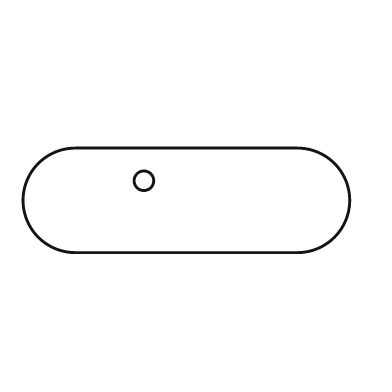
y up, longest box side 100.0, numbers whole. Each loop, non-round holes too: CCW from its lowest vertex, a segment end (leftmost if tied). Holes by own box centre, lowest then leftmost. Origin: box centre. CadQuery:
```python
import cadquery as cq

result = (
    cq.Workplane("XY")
    .moveTo(-34.0, -16.0)
    .lineTo(34.0, -16.0)
    .threePointArc((50.0, 0.0), (34.0, 16.0))
    .lineTo(-34.0, 16.0)
    .threePointArc((-50.0, 0.0), (-34.0, -16.0))
    .close()
    .moveTo(-13.0, 6.0)
    .circle(3.0)
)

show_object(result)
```